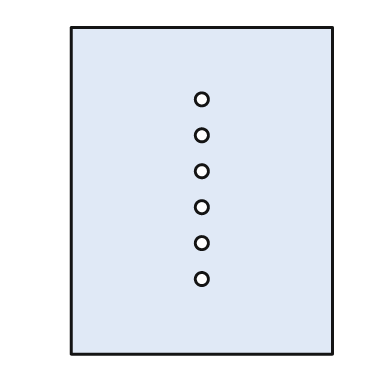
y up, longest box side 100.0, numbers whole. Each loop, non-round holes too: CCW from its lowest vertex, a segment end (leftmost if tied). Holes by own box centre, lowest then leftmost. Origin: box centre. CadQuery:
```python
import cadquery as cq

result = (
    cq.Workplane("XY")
    .moveTo(-40.0, -50.0)
    .lineTo(40.0, -50.0)
    .lineTo(40.0, 50.0)
    .lineTo(-40.0, 50.0)
    .close()
    .moveTo(0.0, -27.0)
    .circle(2.0)
    .moveTo(0.0, -16.0)
    .circle(2.0)
    .moveTo(0.0, -5.0)
    .circle(2.0)
    .moveTo(0.0, 6.0)
    .circle(2.0)
    .moveTo(0.0, 17.0)
    .circle(2.0)
    .moveTo(0.0, 28.0)
    .circle(2.0)
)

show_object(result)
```